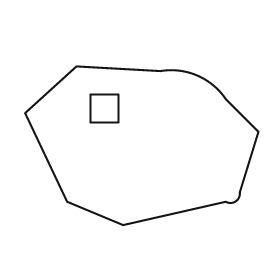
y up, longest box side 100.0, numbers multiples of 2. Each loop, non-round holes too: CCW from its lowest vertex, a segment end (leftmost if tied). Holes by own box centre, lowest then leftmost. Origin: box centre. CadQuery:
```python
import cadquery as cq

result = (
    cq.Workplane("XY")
    .moveTo(-8.0, -34.0)
    .lineTo(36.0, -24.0)
    .threePointArc((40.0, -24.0), (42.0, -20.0))
    .lineTo(50.0, 6.0)
    .lineTo(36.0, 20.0)
    .threePointArc((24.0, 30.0), (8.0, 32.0))
    .lineTo(-28.0, 34.0)
    .lineTo(-50.0, 14.0)
    .lineTo(-32.0, -24.0)
    .close()
    .moveTo(-22.0, 10.0)
    .lineTo(-10.0, 10.0)
    .lineTo(-10.0, 22.0)
    .lineTo(-22.0, 22.0)
    .close()
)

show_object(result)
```